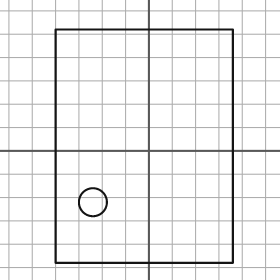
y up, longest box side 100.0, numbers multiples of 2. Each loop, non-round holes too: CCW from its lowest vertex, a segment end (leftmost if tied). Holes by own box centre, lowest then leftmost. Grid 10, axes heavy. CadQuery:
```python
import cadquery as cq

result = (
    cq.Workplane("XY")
    .moveTo(-40.0, -48.0)
    .lineTo(36.0, -48.0)
    .lineTo(36.0, 52.0)
    .lineTo(-40.0, 52.0)
    .close()
    .moveTo(-24.0, -22.0)
    .circle(6.0)
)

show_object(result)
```